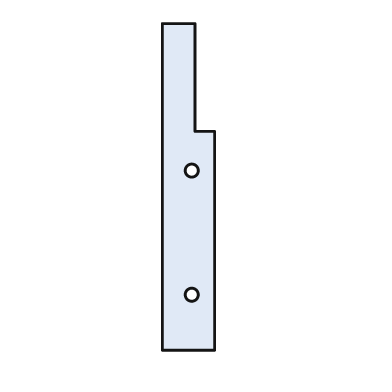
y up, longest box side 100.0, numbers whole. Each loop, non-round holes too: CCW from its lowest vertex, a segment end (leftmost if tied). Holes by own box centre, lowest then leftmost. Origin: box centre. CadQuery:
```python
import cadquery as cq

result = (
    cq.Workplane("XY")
    .moveTo(-8.0, -50.0)
    .lineTo(8.0, -50.0)
    .lineTo(8.0, 17.0)
    .lineTo(2.0, 17.0)
    .lineTo(2.0, 50.0)
    .lineTo(-8.0, 50.0)
    .close()
    .moveTo(1.0, -33.0)
    .circle(2.0)
    .moveTo(1.0, 5.0)
    .circle(2.0)
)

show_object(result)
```